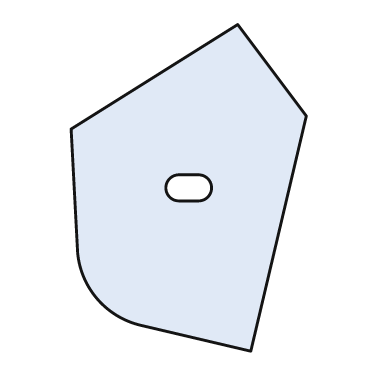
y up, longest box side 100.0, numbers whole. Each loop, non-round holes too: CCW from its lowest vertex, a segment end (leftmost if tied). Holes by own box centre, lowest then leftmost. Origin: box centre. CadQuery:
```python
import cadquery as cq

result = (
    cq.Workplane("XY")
    .moveTo(19.0, -50.0)
    .lineTo(36.0, 22.0)
    .lineTo(15.0, 50.0)
    .lineTo(-36.0, 18.0)
    .lineTo(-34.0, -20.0)
    .threePointArc((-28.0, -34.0), (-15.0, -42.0))
    .close()
    .moveTo(-3.0, -4.0)
    .lineTo(3.0, -4.0)
    .threePointArc((7.0, 0.0), (3.0, 4.0))
    .lineTo(-3.0, 4.0)
    .threePointArc((-7.0, 0.0), (-3.0, -4.0))
    .close()
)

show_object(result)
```